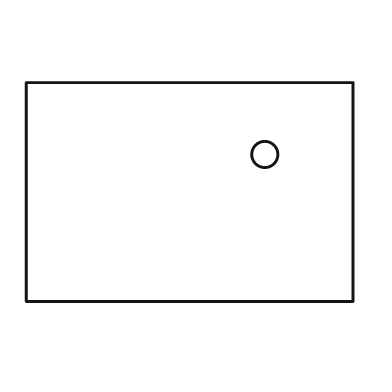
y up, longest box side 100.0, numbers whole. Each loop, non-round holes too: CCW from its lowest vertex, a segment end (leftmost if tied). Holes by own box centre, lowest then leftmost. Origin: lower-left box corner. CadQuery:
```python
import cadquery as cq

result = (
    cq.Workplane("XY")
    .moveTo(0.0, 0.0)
    .lineTo(100.0, 0.0)
    .lineTo(100.0, 67.0)
    .lineTo(0.0, 67.0)
    .close()
    .moveTo(73.0, 45.0)
    .circle(4.0)
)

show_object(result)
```